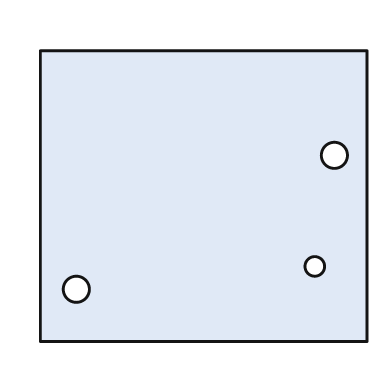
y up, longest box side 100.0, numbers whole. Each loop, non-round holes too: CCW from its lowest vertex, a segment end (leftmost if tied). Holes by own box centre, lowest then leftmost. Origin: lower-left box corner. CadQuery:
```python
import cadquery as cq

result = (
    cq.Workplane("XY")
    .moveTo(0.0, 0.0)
    .lineTo(100.0, 0.0)
    .lineTo(100.0, 89.0)
    .lineTo(0.0, 89.0)
    .close()
    .moveTo(11.0, 16.0)
    .circle(4.0)
    .moveTo(84.0, 23.0)
    .circle(3.0)
    .moveTo(90.0, 57.0)
    .circle(4.0)
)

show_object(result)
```